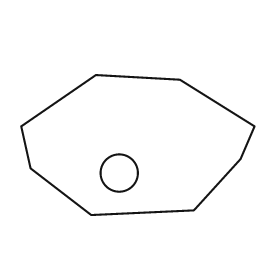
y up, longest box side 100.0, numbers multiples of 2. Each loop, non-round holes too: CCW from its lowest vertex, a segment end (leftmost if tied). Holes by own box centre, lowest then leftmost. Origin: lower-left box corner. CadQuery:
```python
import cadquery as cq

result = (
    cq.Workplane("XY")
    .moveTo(30.0, 0.0)
    .lineTo(74.0, 2.0)
    .lineTo(94.0, 24.0)
    .lineTo(100.0, 38.0)
    .lineTo(68.0, 58.0)
    .lineTo(32.0, 60.0)
    .lineTo(0.0, 38.0)
    .lineTo(4.0, 20.0)
    .close()
    .moveTo(42.0, 18.0)
    .circle(8.0)
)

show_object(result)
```